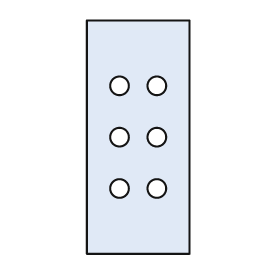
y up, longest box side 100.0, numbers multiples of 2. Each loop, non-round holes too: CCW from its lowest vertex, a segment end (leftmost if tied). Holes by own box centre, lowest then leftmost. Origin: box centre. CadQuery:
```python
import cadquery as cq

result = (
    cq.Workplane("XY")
    .moveTo(-22.0, -50.0)
    .lineTo(22.0, -50.0)
    .lineTo(22.0, 50.0)
    .lineTo(-22.0, 50.0)
    .close()
    .moveTo(-8.0, -22.0)
    .circle(4.0)
    .moveTo(8.0, -22.0)
    .circle(4.0)
    .moveTo(-8.0, 0.0)
    .circle(4.0)
    .moveTo(8.0, 0.0)
    .circle(4.0)
    .moveTo(-8.0, 22.0)
    .circle(4.0)
    .moveTo(8.0, 22.0)
    .circle(4.0)
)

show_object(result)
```